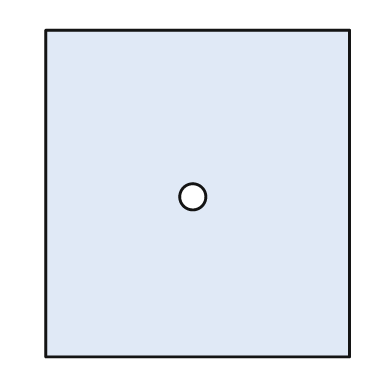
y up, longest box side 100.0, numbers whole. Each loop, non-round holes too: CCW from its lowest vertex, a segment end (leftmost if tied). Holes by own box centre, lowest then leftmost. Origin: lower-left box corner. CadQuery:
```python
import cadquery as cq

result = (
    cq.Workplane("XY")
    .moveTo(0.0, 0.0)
    .lineTo(93.0, 0.0)
    .lineTo(93.0, 100.0)
    .lineTo(0.0, 100.0)
    .close()
    .moveTo(45.0, 49.0)
    .circle(4.0)
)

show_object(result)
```